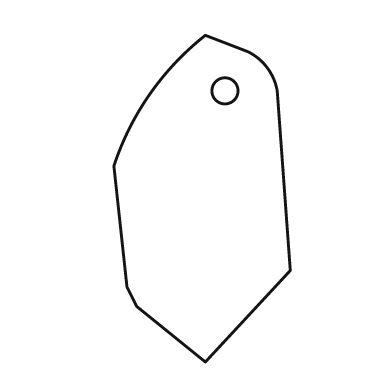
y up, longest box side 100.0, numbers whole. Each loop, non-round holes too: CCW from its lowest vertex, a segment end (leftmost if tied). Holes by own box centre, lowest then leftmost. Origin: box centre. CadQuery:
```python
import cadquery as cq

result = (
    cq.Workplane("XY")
    .moveTo(1.0, -50.0)
    .lineTo(27.0, -22.0)
    .lineTo(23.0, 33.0)
    .threePointArc((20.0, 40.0), (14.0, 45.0))
    .lineTo(1.0, 50.0)
    .threePointArc((-16.0, 32.0), (-27.0, 10.0))
    .lineTo(-23.0, -27.0)
    .lineTo(-20.0, -33.0)
    .close()
    .moveTo(7.0, 33.0)
    .circle(4.0)
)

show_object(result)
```